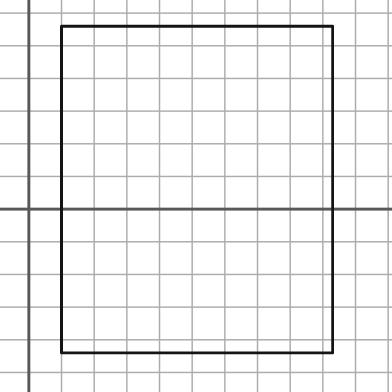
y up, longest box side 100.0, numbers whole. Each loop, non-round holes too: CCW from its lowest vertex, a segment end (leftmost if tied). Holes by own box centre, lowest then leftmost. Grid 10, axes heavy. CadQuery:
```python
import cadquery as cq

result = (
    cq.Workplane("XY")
    .moveTo(10.0, -44.0)
    .lineTo(93.0, -44.0)
    .lineTo(93.0, 56.0)
    .lineTo(10.0, 56.0)
    .close()
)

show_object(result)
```